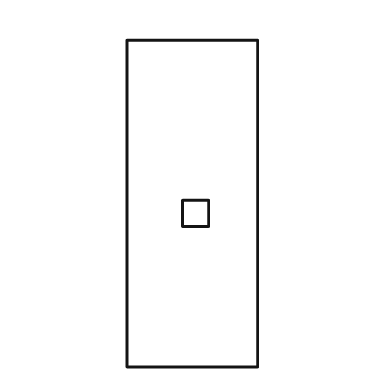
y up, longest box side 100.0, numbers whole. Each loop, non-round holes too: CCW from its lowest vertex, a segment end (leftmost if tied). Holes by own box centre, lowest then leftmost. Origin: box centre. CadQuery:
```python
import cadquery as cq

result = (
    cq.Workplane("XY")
    .moveTo(-20.0, -50.0)
    .lineTo(20.0, -50.0)
    .lineTo(20.0, 50.0)
    .lineTo(-20.0, 50.0)
    .close()
    .moveTo(-3.0, -7.0)
    .lineTo(5.0, -7.0)
    .lineTo(5.0, 1.0)
    .lineTo(-3.0, 1.0)
    .close()
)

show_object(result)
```